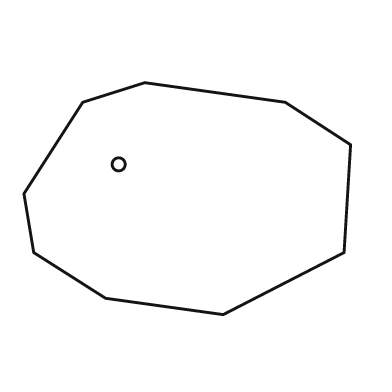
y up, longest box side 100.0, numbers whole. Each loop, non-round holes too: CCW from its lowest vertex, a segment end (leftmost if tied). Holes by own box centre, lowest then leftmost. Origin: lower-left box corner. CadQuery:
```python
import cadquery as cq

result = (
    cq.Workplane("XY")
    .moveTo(61.0, 0.0)
    .lineTo(98.0, 19.0)
    .lineTo(100.0, 52.0)
    .lineTo(80.0, 65.0)
    .lineTo(37.0, 71.0)
    .lineTo(18.0, 65.0)
    .lineTo(0.0, 37.0)
    .lineTo(3.0, 19.0)
    .lineTo(25.0, 5.0)
    .close()
    .moveTo(29.0, 46.0)
    .circle(2.0)
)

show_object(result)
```